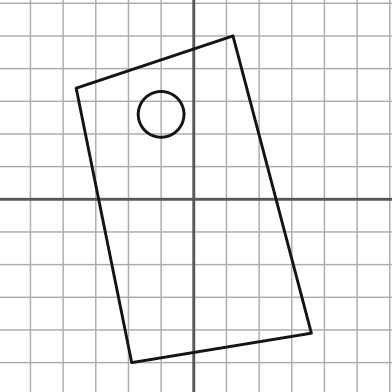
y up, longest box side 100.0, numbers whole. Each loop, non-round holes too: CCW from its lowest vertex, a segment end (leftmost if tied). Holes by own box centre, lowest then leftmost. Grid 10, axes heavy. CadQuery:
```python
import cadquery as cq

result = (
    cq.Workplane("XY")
    .moveTo(-19.0, -50.0)
    .lineTo(36.0, -41.0)
    .lineTo(12.0, 50.0)
    .lineTo(-36.0, 34.0)
    .close()
    .moveTo(-10.0, 26.0)
    .circle(7.0)
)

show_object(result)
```